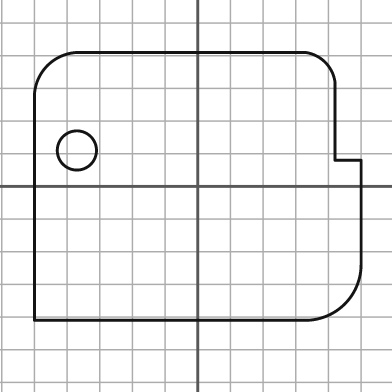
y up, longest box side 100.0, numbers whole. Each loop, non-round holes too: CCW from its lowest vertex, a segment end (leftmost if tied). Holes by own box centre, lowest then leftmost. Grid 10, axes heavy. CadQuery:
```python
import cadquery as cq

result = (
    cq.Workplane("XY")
    .moveTo(-50.0, -41.0)
    .lineTo(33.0, -41.0)
    .threePointArc((45.0, -36.0), (50.0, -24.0))
    .lineTo(50.0, 8.0)
    .lineTo(42.0, 8.0)
    .lineTo(42.0, 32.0)
    .threePointArc((39.0, 38.0), (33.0, 41.0))
    .lineTo(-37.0, 41.0)
    .threePointArc((-46.0, 37.0), (-50.0, 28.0))
    .close()
    .moveTo(-37.0, 11.0)
    .circle(6.0)
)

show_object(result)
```